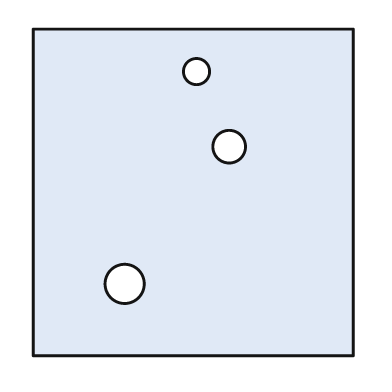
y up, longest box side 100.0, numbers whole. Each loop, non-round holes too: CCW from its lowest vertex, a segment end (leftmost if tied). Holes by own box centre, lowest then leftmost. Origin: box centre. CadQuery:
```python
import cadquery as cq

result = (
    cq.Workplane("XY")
    .moveTo(-49.0, -50.0)
    .lineTo(49.0, -50.0)
    .lineTo(49.0, 50.0)
    .lineTo(-49.0, 50.0)
    .close()
    .moveTo(-21.0, -28.0)
    .circle(6.0)
    .moveTo(11.0, 14.0)
    .circle(5.0)
    .moveTo(1.0, 37.0)
    .circle(4.0)
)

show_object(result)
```